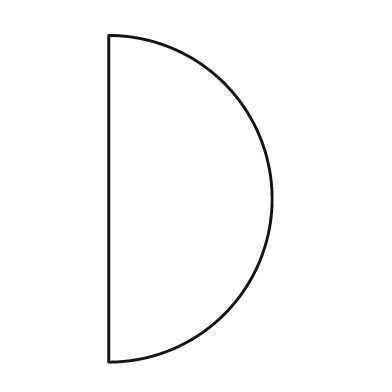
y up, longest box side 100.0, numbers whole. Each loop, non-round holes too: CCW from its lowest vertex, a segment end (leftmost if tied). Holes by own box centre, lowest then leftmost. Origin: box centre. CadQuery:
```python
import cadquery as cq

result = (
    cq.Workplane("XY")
    .moveTo(-25.0, -50.0)
    .threePointArc((25.0, 0.0), (-25.0, 50.0))
    .close()
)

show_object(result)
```